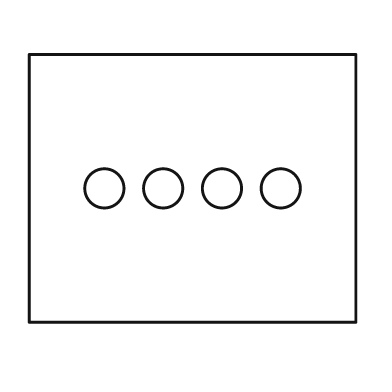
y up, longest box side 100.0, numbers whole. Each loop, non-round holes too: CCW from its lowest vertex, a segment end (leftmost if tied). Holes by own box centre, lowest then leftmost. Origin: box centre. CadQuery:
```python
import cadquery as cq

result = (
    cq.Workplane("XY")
    .moveTo(-50.0, -41.0)
    .lineTo(50.0, -41.0)
    .lineTo(50.0, 41.0)
    .lineTo(-50.0, 41.0)
    .close()
    .moveTo(-27.0, 0.0)
    .circle(6.0)
    .moveTo(-9.0, 0.0)
    .circle(6.0)
    .moveTo(9.0, 0.0)
    .circle(6.0)
    .moveTo(27.0, 0.0)
    .circle(6.0)
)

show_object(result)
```